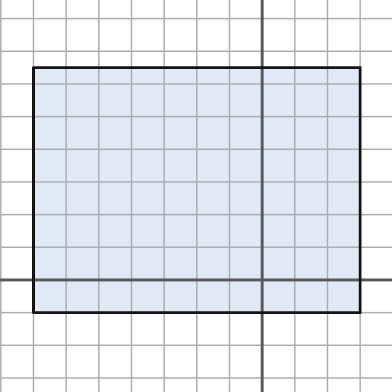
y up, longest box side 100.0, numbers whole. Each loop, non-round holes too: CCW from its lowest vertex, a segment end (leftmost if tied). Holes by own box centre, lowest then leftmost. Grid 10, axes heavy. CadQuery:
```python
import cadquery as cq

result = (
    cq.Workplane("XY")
    .moveTo(-70.0, -10.0)
    .lineTo(30.0, -10.0)
    .lineTo(30.0, 65.0)
    .lineTo(-70.0, 65.0)
    .close()
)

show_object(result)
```